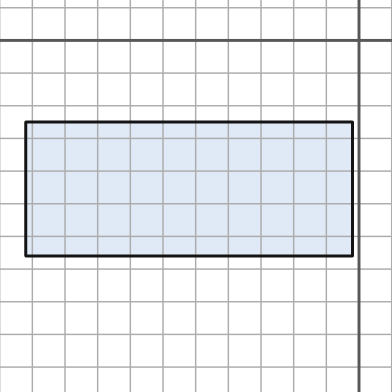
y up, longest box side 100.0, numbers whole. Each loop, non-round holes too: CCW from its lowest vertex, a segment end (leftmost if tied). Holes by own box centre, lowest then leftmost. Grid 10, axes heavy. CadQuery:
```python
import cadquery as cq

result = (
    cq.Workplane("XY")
    .moveTo(-102.0, -66.0)
    .lineTo(-2.0, -66.0)
    .lineTo(-2.0, -25.0)
    .lineTo(-102.0, -25.0)
    .close()
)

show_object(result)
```